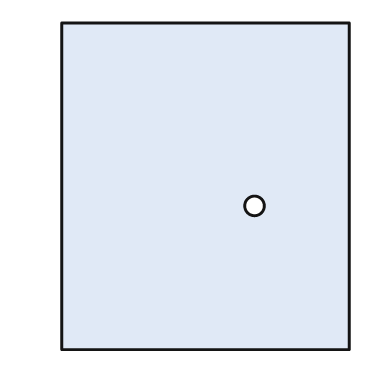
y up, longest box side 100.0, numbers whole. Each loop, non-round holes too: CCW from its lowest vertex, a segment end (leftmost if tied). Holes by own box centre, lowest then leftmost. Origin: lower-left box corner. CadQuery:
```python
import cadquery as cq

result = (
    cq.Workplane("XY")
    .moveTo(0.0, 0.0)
    .lineTo(88.0, 0.0)
    .lineTo(88.0, 100.0)
    .lineTo(0.0, 100.0)
    .close()
    .moveTo(59.0, 44.0)
    .circle(3.0)
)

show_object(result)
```